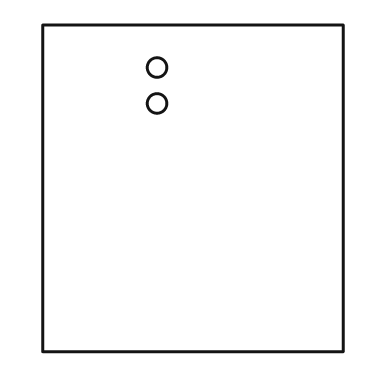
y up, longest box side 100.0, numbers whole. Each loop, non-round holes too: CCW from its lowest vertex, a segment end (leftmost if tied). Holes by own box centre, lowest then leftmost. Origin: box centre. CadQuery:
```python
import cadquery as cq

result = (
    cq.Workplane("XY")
    .moveTo(-46.0, -50.0)
    .lineTo(46.0, -50.0)
    .lineTo(46.0, 50.0)
    .lineTo(-46.0, 50.0)
    .close()
    .moveTo(-11.0, 26.0)
    .circle(3.0)
    .moveTo(-11.0, 37.0)
    .circle(3.0)
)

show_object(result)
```